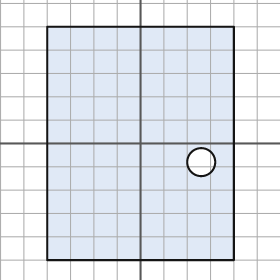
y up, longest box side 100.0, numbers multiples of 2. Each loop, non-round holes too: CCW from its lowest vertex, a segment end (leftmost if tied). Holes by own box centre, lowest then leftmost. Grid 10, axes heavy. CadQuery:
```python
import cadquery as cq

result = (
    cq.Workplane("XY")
    .moveTo(-40.0, -50.0)
    .lineTo(40.0, -50.0)
    .lineTo(40.0, 50.0)
    .lineTo(-40.0, 50.0)
    .close()
    .moveTo(26.0, -8.0)
    .circle(6.0)
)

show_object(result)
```